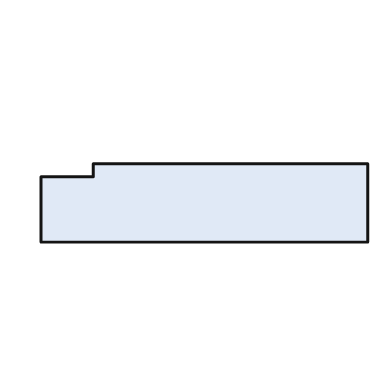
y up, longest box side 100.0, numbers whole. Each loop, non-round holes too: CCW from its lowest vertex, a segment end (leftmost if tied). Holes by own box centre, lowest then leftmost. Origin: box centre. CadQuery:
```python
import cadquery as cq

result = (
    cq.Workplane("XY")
    .moveTo(-50.0, -12.0)
    .lineTo(50.0, -12.0)
    .lineTo(50.0, 12.0)
    .lineTo(-34.0, 12.0)
    .lineTo(-34.0, 8.0)
    .lineTo(-50.0, 8.0)
    .close()
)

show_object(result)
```